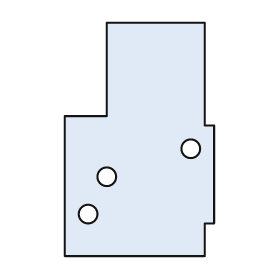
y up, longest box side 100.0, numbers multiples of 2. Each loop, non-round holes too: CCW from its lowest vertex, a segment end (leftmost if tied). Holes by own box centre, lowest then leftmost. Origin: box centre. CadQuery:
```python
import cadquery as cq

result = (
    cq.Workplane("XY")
    .moveTo(-32.0, -50.0)
    .lineTo(28.0, -50.0)
    .lineTo(28.0, -36.0)
    .lineTo(32.0, -36.0)
    .lineTo(32.0, 6.0)
    .lineTo(28.0, 6.0)
    .lineTo(28.0, 50.0)
    .lineTo(-14.0, 50.0)
    .lineTo(-14.0, 10.0)
    .lineTo(-32.0, 10.0)
    .close()
    .moveTo(-22.0, -32.0)
    .circle(4.0)
    .moveTo(-14.0, -16.0)
    .circle(4.0)
    .moveTo(22.0, -4.0)
    .circle(4.0)
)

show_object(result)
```